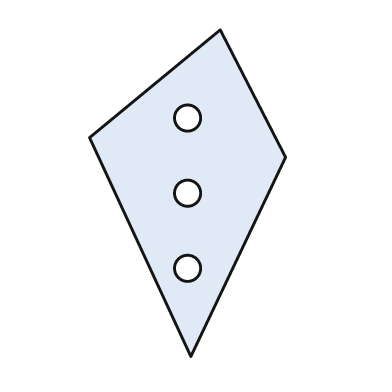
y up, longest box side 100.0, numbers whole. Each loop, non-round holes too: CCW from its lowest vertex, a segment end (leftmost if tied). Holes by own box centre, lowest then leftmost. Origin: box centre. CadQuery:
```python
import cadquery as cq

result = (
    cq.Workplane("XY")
    .moveTo(1.0, -50.0)
    .lineTo(30.0, 11.0)
    .lineTo(10.0, 50.0)
    .lineTo(-30.0, 17.0)
    .close()
    .moveTo(0.0, -23.0)
    .circle(4.0)
    .moveTo(0.0, 0.0)
    .circle(4.0)
    .moveTo(0.0, 23.0)
    .circle(4.0)
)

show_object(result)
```